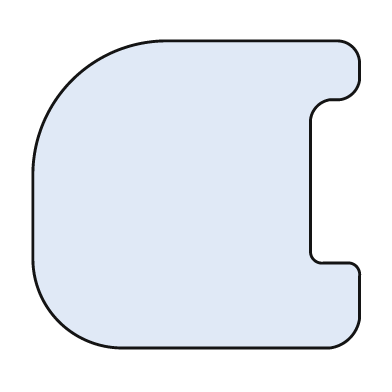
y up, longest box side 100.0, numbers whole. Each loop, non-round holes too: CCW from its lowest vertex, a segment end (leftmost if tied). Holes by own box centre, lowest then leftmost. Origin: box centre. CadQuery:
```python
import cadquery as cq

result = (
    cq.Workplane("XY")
    .moveTo(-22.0, -47.0)
    .lineTo(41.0, -47.0)
    .threePointArc((47.0, -44.0), (50.0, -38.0))
    .lineTo(50.0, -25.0)
    .threePointArc((49.0, -22.0), (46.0, -21.0))
    .lineTo(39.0, -21.0)
    .threePointArc((36.0, -20.0), (35.0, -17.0))
    .lineTo(35.0, 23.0)
    .threePointArc((37.0, 27.0), (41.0, 29.0))
    .lineTo(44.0, 29.0)
    .threePointArc((48.0, 31.0), (50.0, 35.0))
    .lineTo(50.0, 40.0)
    .threePointArc((48.0, 45.0), (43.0, 47.0))
    .lineTo(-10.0, 47.0)
    .threePointArc((-38.0, 35.0), (-50.0, 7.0))
    .lineTo(-50.0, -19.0)
    .threePointArc((-42.0, -39.0), (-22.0, -47.0))
    .close()
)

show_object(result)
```